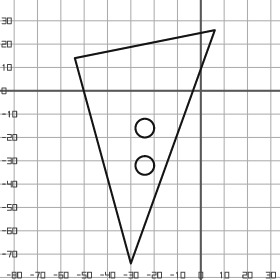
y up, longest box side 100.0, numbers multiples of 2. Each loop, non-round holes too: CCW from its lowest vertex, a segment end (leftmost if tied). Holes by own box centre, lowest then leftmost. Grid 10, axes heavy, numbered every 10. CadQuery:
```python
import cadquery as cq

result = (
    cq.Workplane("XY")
    .moveTo(-30.0, -74.0)
    .lineTo(6.0, 26.0)
    .lineTo(-54.0, 14.0)
    .close()
    .moveTo(-24.0, -32.0)
    .circle(4.0)
    .moveTo(-24.0, -16.0)
    .circle(4.0)
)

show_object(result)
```